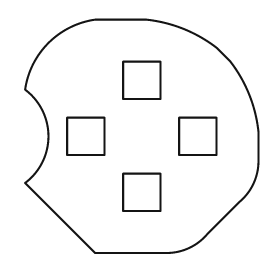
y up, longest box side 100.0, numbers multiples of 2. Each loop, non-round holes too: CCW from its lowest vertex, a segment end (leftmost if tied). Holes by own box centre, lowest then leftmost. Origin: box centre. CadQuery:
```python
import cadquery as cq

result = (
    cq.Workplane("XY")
    .moveTo(-20.0, -50.0)
    .lineTo(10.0, -50.0)
    .threePointArc((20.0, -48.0), (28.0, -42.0))
    .lineTo(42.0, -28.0)
    .threePointArc((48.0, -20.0), (50.0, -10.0))
    .lineTo(50.0, 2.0)
    .threePointArc((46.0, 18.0), (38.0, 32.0))
    .lineTo(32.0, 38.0)
    .threePointArc((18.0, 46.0), (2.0, 50.0))
    .lineTo(-20.0, 50.0)
    .threePointArc((-40.0, 40.0), (-50.0, 20.0))
    .threePointArc((-40.0, 0.0), (-50.0, -20.0))
    .close()
    .moveTo(-8.0, -32.0)
    .lineTo(8.0, -32.0)
    .lineTo(8.0, -16.0)
    .lineTo(-8.0, -16.0)
    .close()
    .moveTo(-32.0, -8.0)
    .lineTo(-16.0, -8.0)
    .lineTo(-16.0, 8.0)
    .lineTo(-32.0, 8.0)
    .close()
    .moveTo(16.0, -8.0)
    .lineTo(32.0, -8.0)
    .lineTo(32.0, 8.0)
    .lineTo(16.0, 8.0)
    .close()
    .moveTo(-8.0, 16.0)
    .lineTo(8.0, 16.0)
    .lineTo(8.0, 32.0)
    .lineTo(-8.0, 32.0)
    .close()
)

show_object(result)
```